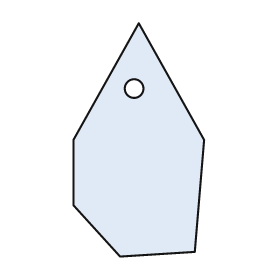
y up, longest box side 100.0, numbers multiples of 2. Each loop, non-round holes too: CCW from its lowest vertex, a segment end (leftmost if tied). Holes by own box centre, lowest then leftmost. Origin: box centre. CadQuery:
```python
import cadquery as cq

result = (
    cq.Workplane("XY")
    .moveTo(-8.0, -50.0)
    .lineTo(24.0, -48.0)
    .lineTo(28.0, 0.0)
    .lineTo(0.0, 50.0)
    .lineTo(-28.0, 0.0)
    .lineTo(-28.0, -28.0)
    .close()
    .moveTo(-2.0, 22.0)
    .circle(4.0)
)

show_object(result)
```